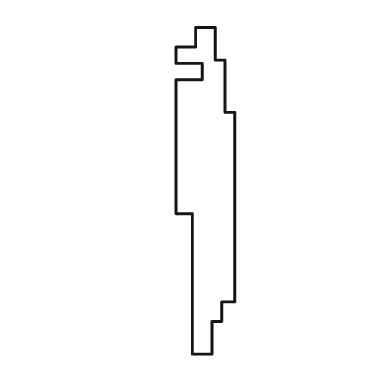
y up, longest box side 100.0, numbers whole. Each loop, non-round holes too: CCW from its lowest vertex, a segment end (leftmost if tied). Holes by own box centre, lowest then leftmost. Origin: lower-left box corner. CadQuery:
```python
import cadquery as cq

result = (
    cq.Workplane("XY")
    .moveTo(5.0, 0.0)
    .lineTo(11.0, 0.0)
    .lineTo(11.0, 10.0)
    .lineTo(14.0, 10.0)
    .lineTo(14.0, 16.0)
    .lineTo(18.0, 16.0)
    .lineTo(18.0, 74.0)
    .lineTo(15.0, 74.0)
    .lineTo(15.0, 90.0)
    .lineTo(12.0, 90.0)
    .lineTo(12.0, 100.0)
    .lineTo(6.0, 100.0)
    .lineTo(6.0, 94.0)
    .lineTo(0.0, 94.0)
    .lineTo(0.0, 89.0)
    .lineTo(8.0, 89.0)
    .lineTo(8.0, 84.0)
    .lineTo(0.0, 84.0)
    .lineTo(0.0, 43.0)
    .lineTo(5.0, 43.0)
    .close()
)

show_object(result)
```